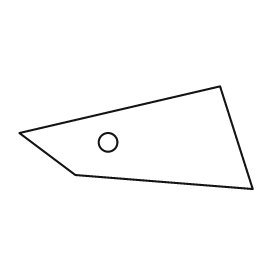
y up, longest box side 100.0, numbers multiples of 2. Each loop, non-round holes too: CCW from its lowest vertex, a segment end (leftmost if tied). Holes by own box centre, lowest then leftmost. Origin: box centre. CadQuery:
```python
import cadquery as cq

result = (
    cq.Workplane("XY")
    .moveTo(50.0, -22.0)
    .lineTo(36.0, 22.0)
    .lineTo(-50.0, 2.0)
    .lineTo(-26.0, -16.0)
    .close()
    .moveTo(-12.0, -2.0)
    .circle(4.0)
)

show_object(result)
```